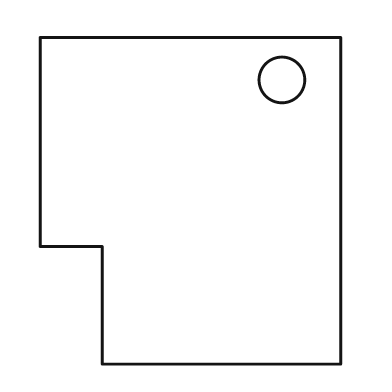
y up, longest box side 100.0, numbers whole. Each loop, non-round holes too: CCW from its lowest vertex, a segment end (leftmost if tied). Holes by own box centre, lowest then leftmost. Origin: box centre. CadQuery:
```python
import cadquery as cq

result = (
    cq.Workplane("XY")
    .moveTo(-27.0, -50.0)
    .lineTo(46.0, -50.0)
    .lineTo(46.0, 50.0)
    .lineTo(-46.0, 50.0)
    .lineTo(-46.0, -14.0)
    .lineTo(-27.0, -14.0)
    .close()
    .moveTo(28.0, 37.0)
    .circle(7.0)
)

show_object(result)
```